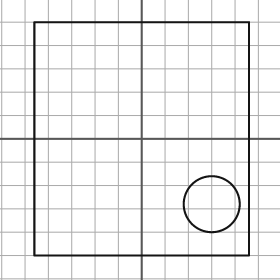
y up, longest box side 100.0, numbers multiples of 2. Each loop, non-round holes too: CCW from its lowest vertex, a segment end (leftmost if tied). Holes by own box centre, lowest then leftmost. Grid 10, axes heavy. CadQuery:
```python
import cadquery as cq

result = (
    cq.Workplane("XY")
    .moveTo(-46.0, -50.0)
    .lineTo(46.0, -50.0)
    .lineTo(46.0, 50.0)
    .lineTo(-46.0, 50.0)
    .close()
    .moveTo(30.0, -28.0)
    .circle(12.0)
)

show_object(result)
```